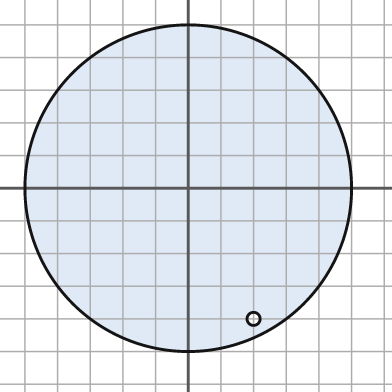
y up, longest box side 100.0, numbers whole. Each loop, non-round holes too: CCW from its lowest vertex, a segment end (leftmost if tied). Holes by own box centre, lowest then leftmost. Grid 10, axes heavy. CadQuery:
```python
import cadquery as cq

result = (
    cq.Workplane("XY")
    .moveTo(0.0, 0.0)
    .circle(50.0)
    .moveTo(20.0, -40.0)
    .circle(2.0)
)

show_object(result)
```